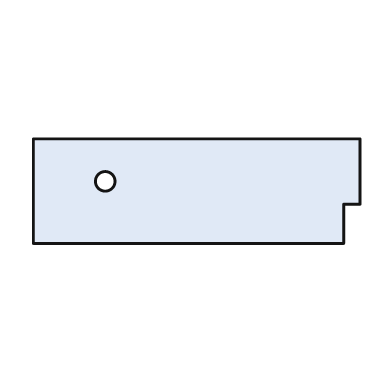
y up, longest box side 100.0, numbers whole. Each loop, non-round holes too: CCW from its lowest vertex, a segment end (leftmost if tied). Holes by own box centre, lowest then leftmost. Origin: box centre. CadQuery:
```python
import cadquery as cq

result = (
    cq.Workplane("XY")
    .moveTo(-50.0, -16.0)
    .lineTo(45.0, -16.0)
    .lineTo(45.0, -4.0)
    .lineTo(50.0, -4.0)
    .lineTo(50.0, 16.0)
    .lineTo(-50.0, 16.0)
    .close()
    .moveTo(-28.0, 3.0)
    .circle(3.0)
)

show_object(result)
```